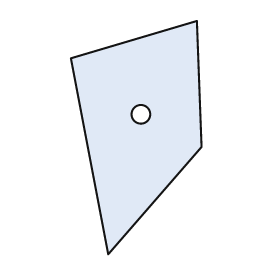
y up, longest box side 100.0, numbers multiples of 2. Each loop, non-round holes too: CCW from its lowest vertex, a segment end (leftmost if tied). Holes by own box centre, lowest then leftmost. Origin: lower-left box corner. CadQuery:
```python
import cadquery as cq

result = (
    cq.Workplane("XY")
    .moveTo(16.0, 0.0)
    .lineTo(56.0, 46.0)
    .lineTo(54.0, 100.0)
    .lineTo(0.0, 84.0)
    .close()
    .moveTo(30.0, 60.0)
    .circle(4.0)
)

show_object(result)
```